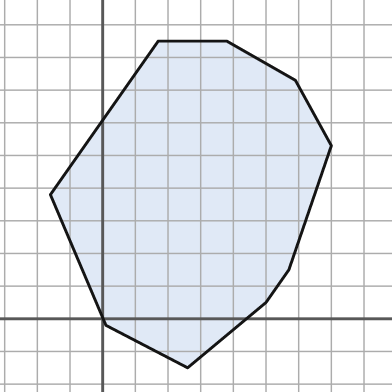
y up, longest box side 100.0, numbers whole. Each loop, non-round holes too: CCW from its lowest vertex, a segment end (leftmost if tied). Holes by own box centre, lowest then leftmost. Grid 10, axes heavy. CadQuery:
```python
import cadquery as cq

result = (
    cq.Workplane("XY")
    .moveTo(26.0, -15.0)
    .lineTo(50.0, 5.0)
    .lineTo(57.0, 15.0)
    .lineTo(70.0, 53.0)
    .lineTo(59.0, 73.0)
    .lineTo(38.0, 85.0)
    .lineTo(17.0, 85.0)
    .lineTo(-16.0, 38.0)
    .lineTo(1.0, -2.0)
    .close()
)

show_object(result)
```